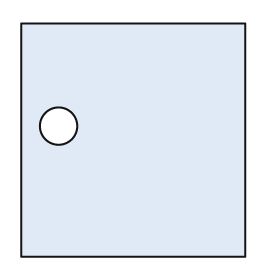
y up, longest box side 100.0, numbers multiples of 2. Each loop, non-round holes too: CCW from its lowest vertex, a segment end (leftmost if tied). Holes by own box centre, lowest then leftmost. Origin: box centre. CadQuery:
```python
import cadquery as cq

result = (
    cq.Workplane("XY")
    .moveTo(-48.0, -50.0)
    .lineTo(48.0, -50.0)
    .lineTo(48.0, 50.0)
    .lineTo(-48.0, 50.0)
    .close()
    .moveTo(-32.0, 6.0)
    .circle(8.0)
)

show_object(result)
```